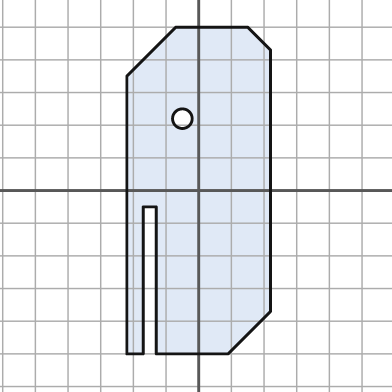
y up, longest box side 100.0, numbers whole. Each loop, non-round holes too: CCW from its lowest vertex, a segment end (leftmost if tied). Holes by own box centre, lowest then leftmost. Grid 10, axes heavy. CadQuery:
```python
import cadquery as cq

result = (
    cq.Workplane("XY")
    .moveTo(-22.0, -50.0)
    .lineTo(-17.0, -50.0)
    .lineTo(-17.0, -5.0)
    .lineTo(-13.0, -5.0)
    .lineTo(-13.0, -50.0)
    .lineTo(9.0, -50.0)
    .lineTo(22.0, -37.0)
    .lineTo(22.0, 43.0)
    .lineTo(15.0, 50.0)
    .lineTo(-7.0, 50.0)
    .lineTo(-22.0, 35.0)
    .close()
    .moveTo(-5.0, 22.0)
    .circle(3.0)
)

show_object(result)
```